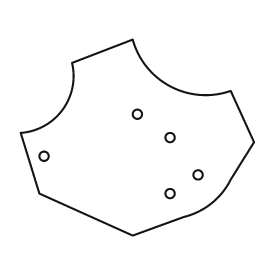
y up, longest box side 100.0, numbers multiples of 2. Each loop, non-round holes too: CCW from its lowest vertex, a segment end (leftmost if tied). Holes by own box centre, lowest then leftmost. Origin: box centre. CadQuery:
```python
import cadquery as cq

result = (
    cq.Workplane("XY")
    .moveTo(-2.0, -42.0)
    .lineTo(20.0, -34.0)
    .threePointArc((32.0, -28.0), (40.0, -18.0))
    .lineTo(50.0, -2.0)
    .lineTo(40.0, 20.0)
    .threePointArc((14.0, 22.0), (-2.0, 42.0))
    .lineTo(-28.0, 32.0)
    .threePointArc((-32.0, 12.0), (-50.0, 2.0))
    .lineTo(-42.0, -24.0)
    .close()
    .moveTo(14.0, -24.0)
    .circle(2.0)
    .moveTo(26.0, -16.0)
    .circle(2.0)
    .moveTo(-40.0, -8.0)
    .circle(2.0)
    .moveTo(14.0, 0.0)
    .circle(2.0)
    .moveTo(0.0, 10.0)
    .circle(2.0)
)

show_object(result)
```